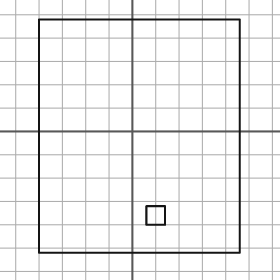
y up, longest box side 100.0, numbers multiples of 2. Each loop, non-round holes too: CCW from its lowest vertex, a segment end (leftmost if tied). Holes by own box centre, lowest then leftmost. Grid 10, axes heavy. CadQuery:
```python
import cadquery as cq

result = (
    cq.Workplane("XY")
    .moveTo(-40.0, -52.0)
    .lineTo(46.0, -52.0)
    .lineTo(46.0, 48.0)
    .lineTo(-40.0, 48.0)
    .close()
    .moveTo(6.0, -40.0)
    .lineTo(14.0, -40.0)
    .lineTo(14.0, -32.0)
    .lineTo(6.0, -32.0)
    .close()
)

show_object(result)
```